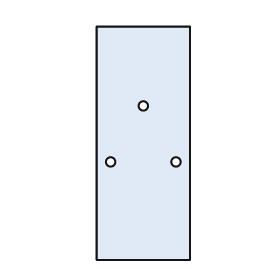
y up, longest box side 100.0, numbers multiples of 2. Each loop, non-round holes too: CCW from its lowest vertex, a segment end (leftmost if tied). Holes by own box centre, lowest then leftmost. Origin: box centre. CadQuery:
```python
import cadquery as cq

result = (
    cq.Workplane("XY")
    .moveTo(-20.0, -50.0)
    .lineTo(20.0, -50.0)
    .lineTo(20.0, 50.0)
    .lineTo(-20.0, 50.0)
    .close()
    .moveTo(-14.0, -8.0)
    .circle(2.0)
    .moveTo(14.0, -8.0)
    .circle(2.0)
    .moveTo(0.0, 16.0)
    .circle(2.0)
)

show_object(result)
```